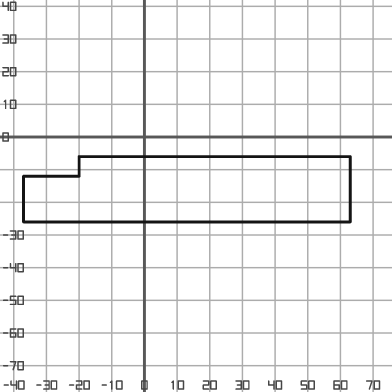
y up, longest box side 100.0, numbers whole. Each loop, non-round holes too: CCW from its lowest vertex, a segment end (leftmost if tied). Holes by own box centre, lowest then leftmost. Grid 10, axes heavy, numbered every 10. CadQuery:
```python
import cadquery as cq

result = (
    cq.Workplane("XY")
    .moveTo(-37.0, -26.0)
    .lineTo(63.0, -26.0)
    .lineTo(63.0, -6.0)
    .lineTo(-20.0, -6.0)
    .lineTo(-20.0, -12.0)
    .lineTo(-37.0, -12.0)
    .close()
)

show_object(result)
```